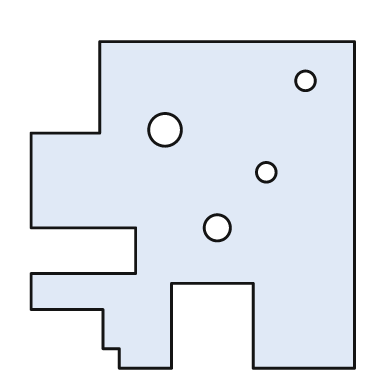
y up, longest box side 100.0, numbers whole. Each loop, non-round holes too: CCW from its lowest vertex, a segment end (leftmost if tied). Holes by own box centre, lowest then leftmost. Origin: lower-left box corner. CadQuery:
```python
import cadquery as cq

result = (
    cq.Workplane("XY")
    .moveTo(27.0, 0.0)
    .lineTo(43.0, 0.0)
    .lineTo(43.0, 26.0)
    .lineTo(68.0, 26.0)
    .lineTo(68.0, 0.0)
    .lineTo(99.0, 0.0)
    .lineTo(99.0, 100.0)
    .lineTo(21.0, 100.0)
    .lineTo(21.0, 72.0)
    .lineTo(0.0, 72.0)
    .lineTo(0.0, 43.0)
    .lineTo(32.0, 43.0)
    .lineTo(32.0, 29.0)
    .lineTo(0.0, 29.0)
    .lineTo(0.0, 18.0)
    .lineTo(22.0, 18.0)
    .lineTo(22.0, 6.0)
    .lineTo(27.0, 6.0)
    .close()
    .moveTo(57.0, 43.0)
    .circle(4.0)
    .moveTo(72.0, 60.0)
    .circle(3.0)
    .moveTo(41.0, 73.0)
    .circle(5.0)
    .moveTo(84.0, 88.0)
    .circle(3.0)
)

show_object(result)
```